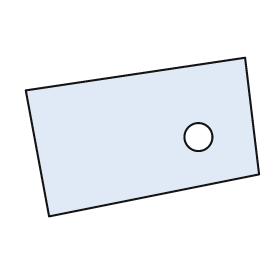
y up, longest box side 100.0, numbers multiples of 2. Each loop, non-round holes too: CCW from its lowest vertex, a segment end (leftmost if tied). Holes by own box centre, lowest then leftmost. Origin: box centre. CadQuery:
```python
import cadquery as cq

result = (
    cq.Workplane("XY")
    .moveTo(-40.0, -34.0)
    .lineTo(50.0, -16.0)
    .lineTo(44.0, 34.0)
    .lineTo(-50.0, 20.0)
    .close()
    .moveTo(24.0, 0.0)
    .circle(6.0)
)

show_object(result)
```